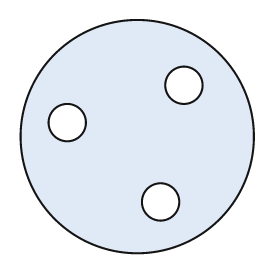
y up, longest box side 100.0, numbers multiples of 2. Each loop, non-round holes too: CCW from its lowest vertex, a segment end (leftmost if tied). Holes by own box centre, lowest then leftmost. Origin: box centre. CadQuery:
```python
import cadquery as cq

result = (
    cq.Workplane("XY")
    .moveTo(0.0, 0.0)
    .circle(50.0)
    .moveTo(10.0, -28.0)
    .circle(8.0)
    .moveTo(-30.0, 6.0)
    .circle(8.0)
    .moveTo(20.0, 22.0)
    .circle(8.0)
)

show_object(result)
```